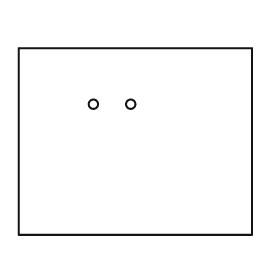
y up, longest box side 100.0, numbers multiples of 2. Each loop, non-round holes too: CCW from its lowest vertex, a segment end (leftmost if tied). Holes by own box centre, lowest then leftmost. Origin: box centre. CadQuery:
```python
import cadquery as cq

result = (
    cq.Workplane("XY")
    .moveTo(-50.0, -40.0)
    .lineTo(50.0, -40.0)
    .lineTo(50.0, 40.0)
    .lineTo(-50.0, 40.0)
    .close()
    .moveTo(-18.0, 16.0)
    .circle(2.0)
    .moveTo(-2.0, 16.0)
    .circle(2.0)
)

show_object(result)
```